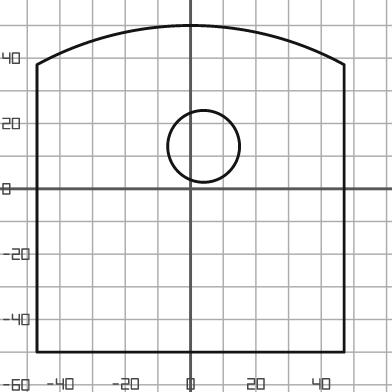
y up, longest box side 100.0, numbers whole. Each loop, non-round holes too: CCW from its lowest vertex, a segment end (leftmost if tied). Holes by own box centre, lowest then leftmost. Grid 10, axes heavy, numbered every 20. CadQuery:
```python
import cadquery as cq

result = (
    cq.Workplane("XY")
    .moveTo(-47.0, -50.0)
    .lineTo(47.0, -50.0)
    .lineTo(47.0, 38.0)
    .threePointArc((0.0, 50.0), (-47.0, 38.0))
    .close()
    .moveTo(4.0, 13.0)
    .circle(11.0)
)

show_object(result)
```